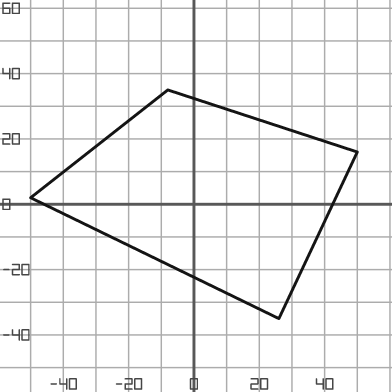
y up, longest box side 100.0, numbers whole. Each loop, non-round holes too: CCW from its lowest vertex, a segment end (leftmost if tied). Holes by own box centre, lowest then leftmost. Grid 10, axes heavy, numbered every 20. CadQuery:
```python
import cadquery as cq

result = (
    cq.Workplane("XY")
    .moveTo(26.0, -35.0)
    .lineTo(50.0, 16.0)
    .lineTo(-8.0, 35.0)
    .lineTo(-50.0, 2.0)
    .close()
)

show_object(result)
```